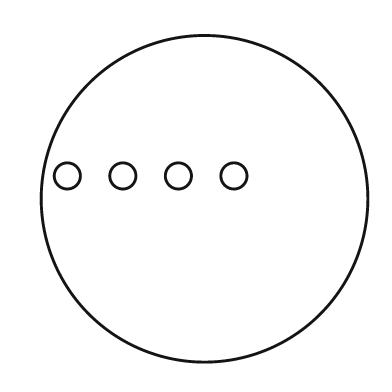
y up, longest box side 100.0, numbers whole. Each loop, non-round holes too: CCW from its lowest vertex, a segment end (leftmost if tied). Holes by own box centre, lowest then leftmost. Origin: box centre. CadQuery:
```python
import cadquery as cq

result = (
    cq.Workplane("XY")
    .moveTo(0.0, 0.0)
    .circle(50.0)
    .moveTo(-42.0, 7.0)
    .circle(4.0)
    .moveTo(-25.0, 7.0)
    .circle(4.0)
    .moveTo(-8.0, 7.0)
    .circle(4.0)
    .moveTo(9.0, 7.0)
    .circle(4.0)
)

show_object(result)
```